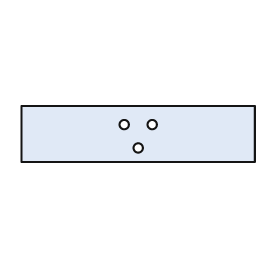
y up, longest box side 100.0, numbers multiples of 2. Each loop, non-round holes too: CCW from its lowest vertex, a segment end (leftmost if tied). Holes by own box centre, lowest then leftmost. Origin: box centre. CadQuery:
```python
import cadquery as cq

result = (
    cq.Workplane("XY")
    .moveTo(-50.0, -12.0)
    .lineTo(50.0, -12.0)
    .lineTo(50.0, 12.0)
    .lineTo(-50.0, 12.0)
    .close()
    .moveTo(0.0, -6.0)
    .circle(2.0)
    .moveTo(-6.0, 4.0)
    .circle(2.0)
    .moveTo(6.0, 4.0)
    .circle(2.0)
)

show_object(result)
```